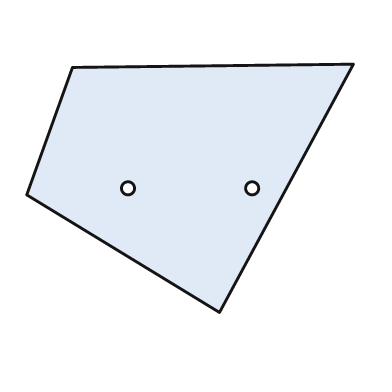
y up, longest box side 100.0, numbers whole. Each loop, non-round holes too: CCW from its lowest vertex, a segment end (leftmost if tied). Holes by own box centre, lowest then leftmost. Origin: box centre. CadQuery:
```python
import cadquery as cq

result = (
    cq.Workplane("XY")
    .moveTo(9.0, -38.0)
    .lineTo(50.0, 38.0)
    .lineTo(-36.0, 37.0)
    .lineTo(-50.0, -2.0)
    .close()
    .moveTo(-19.0, 0.0)
    .circle(2.0)
    .moveTo(19.0, 0.0)
    .circle(2.0)
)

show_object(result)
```